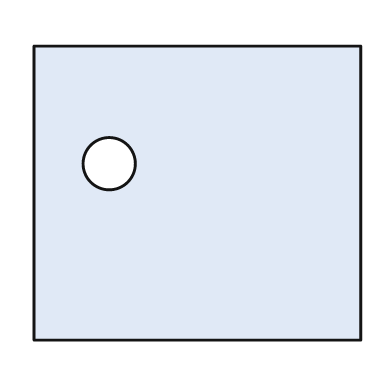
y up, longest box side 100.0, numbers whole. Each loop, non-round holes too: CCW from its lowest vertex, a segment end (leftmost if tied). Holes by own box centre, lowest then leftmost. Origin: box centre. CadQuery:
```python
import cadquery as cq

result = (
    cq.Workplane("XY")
    .moveTo(-50.0, -45.0)
    .lineTo(50.0, -45.0)
    .lineTo(50.0, 45.0)
    .lineTo(-50.0, 45.0)
    .close()
    .moveTo(-27.0, 9.0)
    .circle(8.0)
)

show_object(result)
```